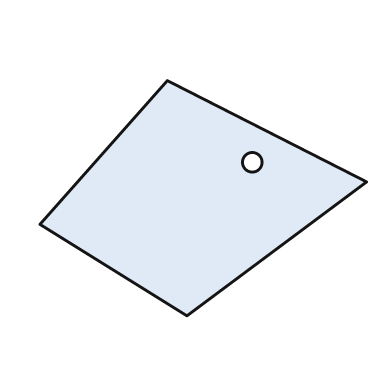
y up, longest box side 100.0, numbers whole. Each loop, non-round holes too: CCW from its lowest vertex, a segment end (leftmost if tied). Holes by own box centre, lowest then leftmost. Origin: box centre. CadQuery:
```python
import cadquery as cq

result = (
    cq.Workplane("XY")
    .moveTo(-5.0, -36.0)
    .lineTo(50.0, 5.0)
    .lineTo(-11.0, 36.0)
    .lineTo(-50.0, -8.0)
    .close()
    .moveTo(15.0, 11.0)
    .circle(3.0)
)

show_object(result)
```